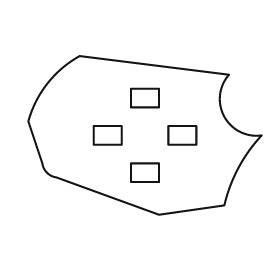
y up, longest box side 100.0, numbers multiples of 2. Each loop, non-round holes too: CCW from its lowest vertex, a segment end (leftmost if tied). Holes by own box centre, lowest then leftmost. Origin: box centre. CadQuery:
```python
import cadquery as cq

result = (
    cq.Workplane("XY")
    .moveTo(6.0, -34.0)
    .lineTo(34.0, -30.0)
    .threePointArc((40.0, -14.0), (50.0, 0.0))
    .threePointArc((34.0, 8.0), (36.0, 26.0))
    .lineTo(-28.0, 34.0)
    .threePointArc((-42.0, 22.0), (-50.0, 6.0))
    .lineTo(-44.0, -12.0)
    .threePointArc((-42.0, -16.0), (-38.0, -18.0))
    .close()
    .moveTo(-6.0, -20.0)
    .lineTo(6.0, -20.0)
    .lineTo(6.0, -12.0)
    .lineTo(-6.0, -12.0)
    .close()
    .moveTo(-22.0, -4.0)
    .lineTo(-10.0, -4.0)
    .lineTo(-10.0, 4.0)
    .lineTo(-22.0, 4.0)
    .close()
    .moveTo(10.0, -4.0)
    .lineTo(22.0, -4.0)
    .lineTo(22.0, 4.0)
    .lineTo(10.0, 4.0)
    .close()
    .moveTo(-6.0, 12.0)
    .lineTo(6.0, 12.0)
    .lineTo(6.0, 20.0)
    .lineTo(-6.0, 20.0)
    .close()
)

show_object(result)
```